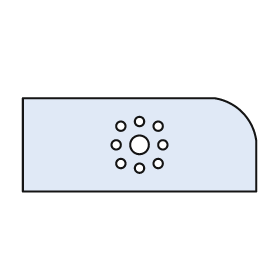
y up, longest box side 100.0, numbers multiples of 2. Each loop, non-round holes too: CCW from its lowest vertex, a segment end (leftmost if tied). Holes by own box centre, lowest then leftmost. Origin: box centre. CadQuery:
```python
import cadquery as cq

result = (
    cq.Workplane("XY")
    .moveTo(-50.0, -20.0)
    .lineTo(50.0, -20.0)
    .lineTo(50.0, 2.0)
    .threePointArc((44.0, 14.0), (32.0, 20.0))
    .lineTo(-50.0, 20.0)
    .close()
    .moveTo(0.0, -10.0)
    .circle(2.0)
    .moveTo(-8.0, -8.0)
    .circle(2.0)
    .moveTo(8.0, -8.0)
    .circle(2.0)
    .moveTo(-10.0, 0.0)
    .circle(2.0)
    .moveTo(0.0, 0.0)
    .circle(4.0)
    .moveTo(10.0, 0.0)
    .circle(2.0)
    .moveTo(-8.0, 8.0)
    .circle(2.0)
    .moveTo(8.0, 8.0)
    .circle(2.0)
    .moveTo(0.0, 10.0)
    .circle(2.0)
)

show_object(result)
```